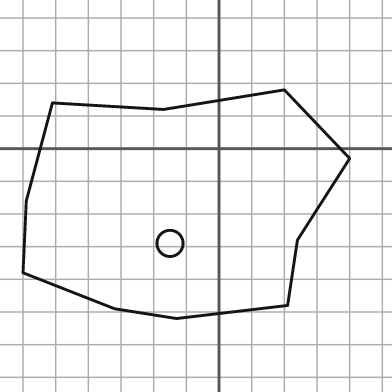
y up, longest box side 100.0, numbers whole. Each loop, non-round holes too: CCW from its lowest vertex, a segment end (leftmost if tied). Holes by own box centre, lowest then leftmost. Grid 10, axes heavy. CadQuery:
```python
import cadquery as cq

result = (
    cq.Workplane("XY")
    .moveTo(-13.0, -52.0)
    .lineTo(21.0, -48.0)
    .lineTo(24.0, -28.0)
    .lineTo(40.0, -3.0)
    .lineTo(20.0, 18.0)
    .lineTo(-17.0, 12.0)
    .lineTo(-51.0, 14.0)
    .lineTo(-59.0, -16.0)
    .lineTo(-60.0, -38.0)
    .lineTo(-32.0, -49.0)
    .close()
    .moveTo(-15.0, -29.0)
    .circle(4.0)
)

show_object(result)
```